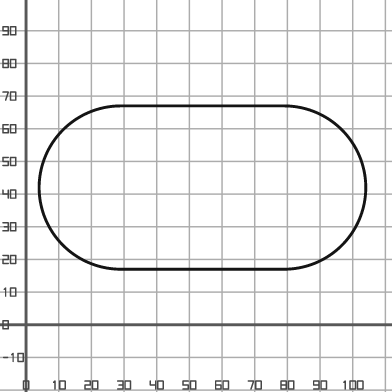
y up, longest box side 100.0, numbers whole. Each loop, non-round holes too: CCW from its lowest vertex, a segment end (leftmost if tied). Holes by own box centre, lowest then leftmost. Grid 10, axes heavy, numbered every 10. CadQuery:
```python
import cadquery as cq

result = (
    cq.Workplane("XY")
    .moveTo(29.0, 17.0)
    .lineTo(79.0, 17.0)
    .threePointArc((104.0, 42.0), (79.0, 67.0))
    .lineTo(29.0, 67.0)
    .threePointArc((4.0, 42.0), (29.0, 17.0))
    .close()
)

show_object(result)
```